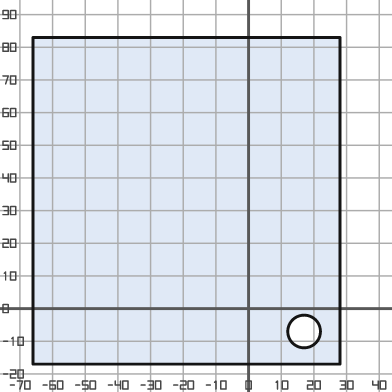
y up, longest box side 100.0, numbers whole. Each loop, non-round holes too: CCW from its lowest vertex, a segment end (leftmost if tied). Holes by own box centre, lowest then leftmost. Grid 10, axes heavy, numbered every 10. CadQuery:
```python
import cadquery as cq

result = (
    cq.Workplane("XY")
    .moveTo(-66.0, -17.0)
    .lineTo(28.0, -17.0)
    .lineTo(28.0, 83.0)
    .lineTo(-66.0, 83.0)
    .close()
    .moveTo(17.0, -7.0)
    .circle(5.0)
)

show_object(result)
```